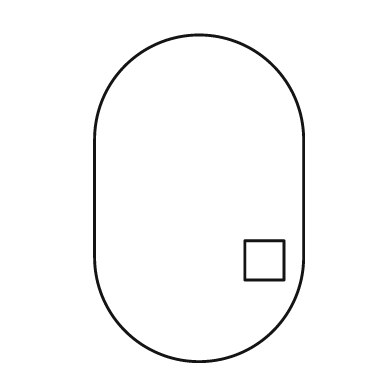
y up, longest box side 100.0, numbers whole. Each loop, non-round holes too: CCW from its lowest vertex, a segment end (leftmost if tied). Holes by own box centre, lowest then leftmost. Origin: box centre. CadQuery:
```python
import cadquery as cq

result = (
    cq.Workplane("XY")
    .moveTo(-32.0, -18.0)
    .threePointArc((0.0, -50.0), (32.0, -18.0))
    .lineTo(32.0, 18.0)
    .threePointArc((0.0, 50.0), (-32.0, 18.0))
    .close()
    .moveTo(14.0, -25.0)
    .lineTo(26.0, -25.0)
    .lineTo(26.0, -13.0)
    .lineTo(14.0, -13.0)
    .close()
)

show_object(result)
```